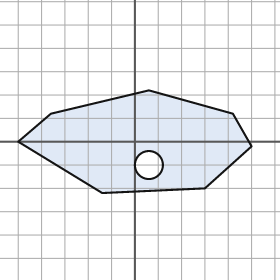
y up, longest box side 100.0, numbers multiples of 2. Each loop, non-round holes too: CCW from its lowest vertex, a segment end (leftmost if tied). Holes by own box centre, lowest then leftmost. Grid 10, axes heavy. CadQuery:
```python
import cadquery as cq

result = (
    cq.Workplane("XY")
    .moveTo(-14.0, -22.0)
    .lineTo(30.0, -20.0)
    .lineTo(50.0, -2.0)
    .lineTo(42.0, 12.0)
    .lineTo(6.0, 22.0)
    .lineTo(-36.0, 12.0)
    .lineTo(-50.0, 0.0)
    .close()
    .moveTo(6.0, -10.0)
    .circle(6.0)
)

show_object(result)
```